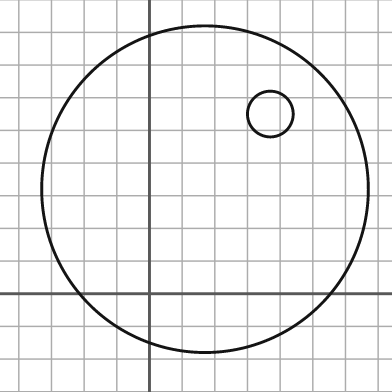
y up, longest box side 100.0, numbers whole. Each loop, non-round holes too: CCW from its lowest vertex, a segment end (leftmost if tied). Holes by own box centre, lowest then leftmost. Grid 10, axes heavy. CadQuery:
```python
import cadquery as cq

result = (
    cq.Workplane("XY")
    .moveTo(17.0, 32.0)
    .circle(50.0)
    .moveTo(37.0, 55.0)
    .circle(7.0)
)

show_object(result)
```